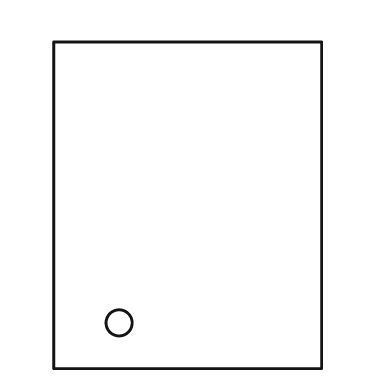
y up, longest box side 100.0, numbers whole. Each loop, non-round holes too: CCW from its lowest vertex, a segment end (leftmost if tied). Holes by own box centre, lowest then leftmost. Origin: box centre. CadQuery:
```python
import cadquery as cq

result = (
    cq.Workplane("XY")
    .moveTo(-41.0, -50.0)
    .lineTo(41.0, -50.0)
    .lineTo(41.0, 50.0)
    .lineTo(-41.0, 50.0)
    .close()
    .moveTo(-21.0, -36.0)
    .circle(4.0)
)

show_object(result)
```